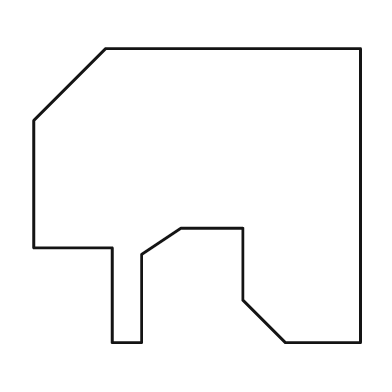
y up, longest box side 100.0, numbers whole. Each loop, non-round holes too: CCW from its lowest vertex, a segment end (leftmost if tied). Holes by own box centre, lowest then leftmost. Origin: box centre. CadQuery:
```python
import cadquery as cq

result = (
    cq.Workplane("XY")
    .moveTo(-26.0, -45.0)
    .lineTo(-17.0, -45.0)
    .lineTo(-17.0, -18.0)
    .lineTo(-5.0, -10.0)
    .lineTo(14.0, -10.0)
    .lineTo(14.0, -32.0)
    .lineTo(27.0, -45.0)
    .lineTo(50.0, -45.0)
    .lineTo(50.0, 45.0)
    .lineTo(-28.0, 45.0)
    .lineTo(-50.0, 23.0)
    .lineTo(-50.0, -16.0)
    .lineTo(-26.0, -16.0)
    .close()
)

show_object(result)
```